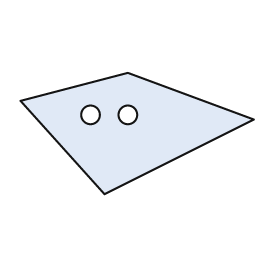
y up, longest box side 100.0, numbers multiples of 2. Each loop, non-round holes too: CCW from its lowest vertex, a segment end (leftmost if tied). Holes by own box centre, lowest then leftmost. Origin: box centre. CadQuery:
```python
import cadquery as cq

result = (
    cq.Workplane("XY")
    .moveTo(-14.0, -26.0)
    .lineTo(50.0, 6.0)
    .lineTo(-4.0, 26.0)
    .lineTo(-50.0, 14.0)
    .close()
    .moveTo(-20.0, 8.0)
    .circle(4.0)
    .moveTo(-4.0, 8.0)
    .circle(4.0)
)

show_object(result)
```